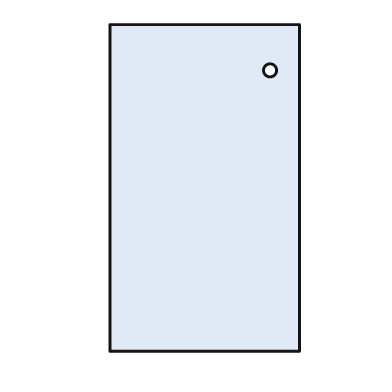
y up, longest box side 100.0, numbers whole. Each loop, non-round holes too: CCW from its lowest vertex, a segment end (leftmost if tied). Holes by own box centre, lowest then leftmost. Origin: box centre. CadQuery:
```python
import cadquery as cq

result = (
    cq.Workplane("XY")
    .moveTo(-29.0, -50.0)
    .lineTo(29.0, -50.0)
    .lineTo(29.0, 50.0)
    .lineTo(-29.0, 50.0)
    .close()
    .moveTo(20.0, 36.0)
    .circle(2.0)
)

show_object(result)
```